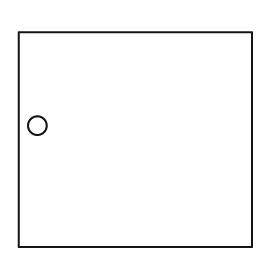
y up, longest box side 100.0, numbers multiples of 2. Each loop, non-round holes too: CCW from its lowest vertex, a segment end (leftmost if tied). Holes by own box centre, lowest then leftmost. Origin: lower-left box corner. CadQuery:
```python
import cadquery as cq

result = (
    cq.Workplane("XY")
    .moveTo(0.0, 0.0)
    .lineTo(100.0, 0.0)
    .lineTo(100.0, 92.0)
    .lineTo(0.0, 92.0)
    .close()
    .moveTo(8.0, 52.0)
    .circle(4.0)
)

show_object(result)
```